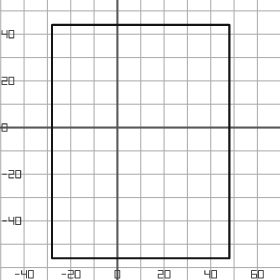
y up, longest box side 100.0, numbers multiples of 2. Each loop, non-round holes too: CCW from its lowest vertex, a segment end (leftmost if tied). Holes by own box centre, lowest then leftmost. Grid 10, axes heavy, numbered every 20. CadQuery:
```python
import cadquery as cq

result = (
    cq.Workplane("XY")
    .moveTo(-28.0, -56.0)
    .lineTo(48.0, -56.0)
    .lineTo(48.0, 44.0)
    .lineTo(-28.0, 44.0)
    .close()
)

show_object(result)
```